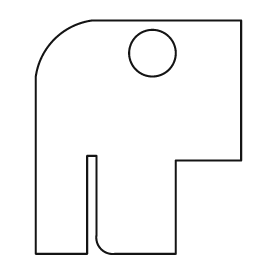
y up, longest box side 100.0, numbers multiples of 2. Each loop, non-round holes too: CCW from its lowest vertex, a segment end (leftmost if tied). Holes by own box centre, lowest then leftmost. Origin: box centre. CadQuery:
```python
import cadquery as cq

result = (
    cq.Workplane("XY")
    .moveTo(-44.0, -50.0)
    .lineTo(-22.0, -50.0)
    .lineTo(-22.0, -8.0)
    .lineTo(-18.0, -8.0)
    .lineTo(-18.0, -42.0)
    .threePointArc((-16.0, -48.0), (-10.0, -50.0))
    .lineTo(16.0, -50.0)
    .lineTo(16.0, -10.0)
    .lineTo(44.0, -10.0)
    .lineTo(44.0, 50.0)
    .lineTo(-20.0, 50.0)
    .threePointArc((-36.0, 42.0), (-44.0, 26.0))
    .close()
    .moveTo(6.0, 36.0)
    .circle(10.0)
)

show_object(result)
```